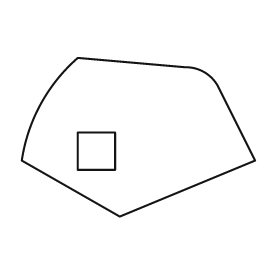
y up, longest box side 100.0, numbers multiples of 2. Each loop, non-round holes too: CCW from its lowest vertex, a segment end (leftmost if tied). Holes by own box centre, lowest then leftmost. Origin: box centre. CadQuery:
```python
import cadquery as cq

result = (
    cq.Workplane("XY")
    .moveTo(-8.0, -34.0)
    .lineTo(50.0, -10.0)
    .lineTo(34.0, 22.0)
    .threePointArc((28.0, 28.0), (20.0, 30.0))
    .lineTo(-26.0, 34.0)
    .threePointArc((-42.0, 14.0), (-50.0, -10.0))
    .close()
    .moveTo(-26.0, -14.0)
    .lineTo(-10.0, -14.0)
    .lineTo(-10.0, 2.0)
    .lineTo(-26.0, 2.0)
    .close()
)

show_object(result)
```